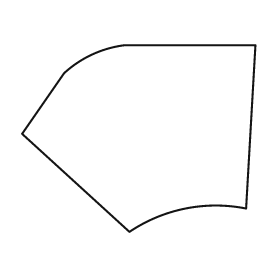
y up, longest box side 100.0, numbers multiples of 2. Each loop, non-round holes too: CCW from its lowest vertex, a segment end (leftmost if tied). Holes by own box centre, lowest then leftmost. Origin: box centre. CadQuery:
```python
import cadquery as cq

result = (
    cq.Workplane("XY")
    .moveTo(-4.0, -40.0)
    .threePointArc((20.0, -30.0), (46.0, -30.0))
    .lineTo(50.0, 40.0)
    .lineTo(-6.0, 40.0)
    .threePointArc((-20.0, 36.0), (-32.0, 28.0))
    .lineTo(-50.0, 2.0)
    .close()
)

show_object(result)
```